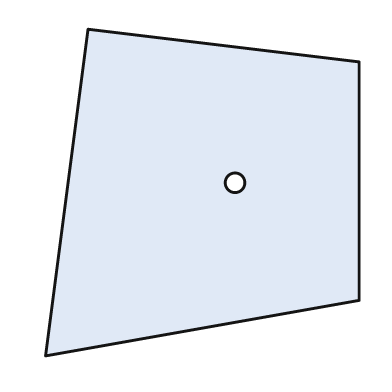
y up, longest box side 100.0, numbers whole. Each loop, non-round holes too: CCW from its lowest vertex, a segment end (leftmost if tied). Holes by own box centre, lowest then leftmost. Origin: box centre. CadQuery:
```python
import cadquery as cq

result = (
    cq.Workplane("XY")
    .moveTo(-48.0, -50.0)
    .lineTo(48.0, -33.0)
    .lineTo(48.0, 40.0)
    .lineTo(-35.0, 50.0)
    .close()
    .moveTo(10.0, 3.0)
    .circle(3.0)
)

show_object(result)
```